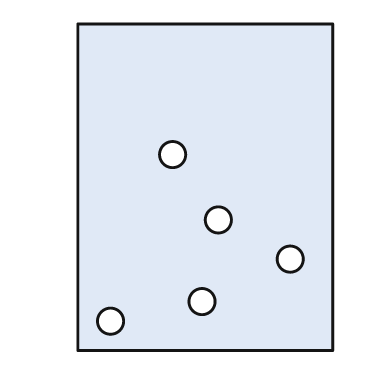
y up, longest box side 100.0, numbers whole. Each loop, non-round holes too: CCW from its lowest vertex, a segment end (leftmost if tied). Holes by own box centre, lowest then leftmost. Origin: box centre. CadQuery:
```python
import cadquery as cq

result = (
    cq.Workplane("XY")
    .moveTo(-39.0, -50.0)
    .lineTo(39.0, -50.0)
    .lineTo(39.0, 50.0)
    .lineTo(-39.0, 50.0)
    .close()
    .moveTo(-29.0, -41.0)
    .circle(4.0)
    .moveTo(-1.0, -35.0)
    .circle(4.0)
    .moveTo(26.0, -22.0)
    .circle(4.0)
    .moveTo(4.0, -10.0)
    .circle(4.0)
    .moveTo(-10.0, 10.0)
    .circle(4.0)
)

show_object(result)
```